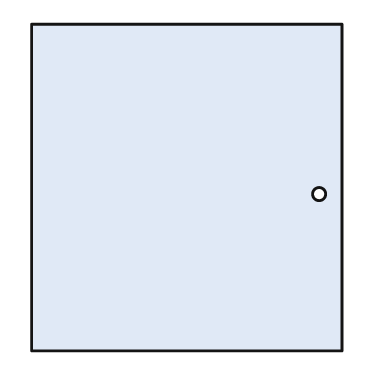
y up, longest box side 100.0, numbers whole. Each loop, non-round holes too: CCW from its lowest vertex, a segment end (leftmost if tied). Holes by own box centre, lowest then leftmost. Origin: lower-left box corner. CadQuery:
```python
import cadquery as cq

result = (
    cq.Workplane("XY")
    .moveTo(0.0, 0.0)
    .lineTo(95.0, 0.0)
    .lineTo(95.0, 100.0)
    .lineTo(0.0, 100.0)
    .close()
    .moveTo(88.0, 48.0)
    .circle(2.0)
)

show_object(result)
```